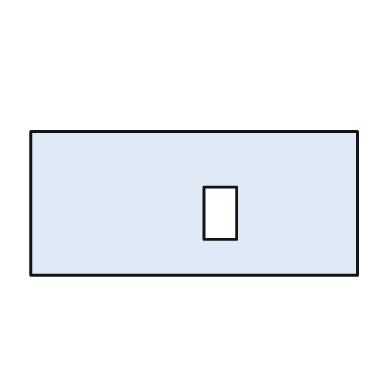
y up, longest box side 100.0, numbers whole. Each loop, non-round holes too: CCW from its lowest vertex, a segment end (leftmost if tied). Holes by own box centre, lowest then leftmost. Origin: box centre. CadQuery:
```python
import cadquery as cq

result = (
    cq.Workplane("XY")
    .moveTo(-50.0, -22.0)
    .lineTo(50.0, -22.0)
    .lineTo(50.0, 22.0)
    .lineTo(-50.0, 22.0)
    .close()
    .moveTo(3.0, -11.0)
    .lineTo(13.0, -11.0)
    .lineTo(13.0, 5.0)
    .lineTo(3.0, 5.0)
    .close()
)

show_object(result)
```